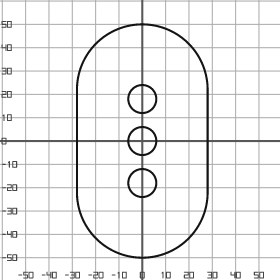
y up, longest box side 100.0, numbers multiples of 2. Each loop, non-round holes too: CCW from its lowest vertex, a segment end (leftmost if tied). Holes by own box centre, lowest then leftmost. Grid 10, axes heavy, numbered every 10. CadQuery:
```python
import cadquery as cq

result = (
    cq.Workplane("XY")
    .moveTo(-28.0, -22.0)
    .threePointArc((0.0, -50.0), (28.0, -22.0))
    .lineTo(28.0, 22.0)
    .threePointArc((0.0, 50.0), (-28.0, 22.0))
    .close()
    .moveTo(0.0, -18.0)
    .circle(6.0)
    .moveTo(0.0, 0.0)
    .circle(6.0)
    .moveTo(0.0, 18.0)
    .circle(6.0)
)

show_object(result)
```